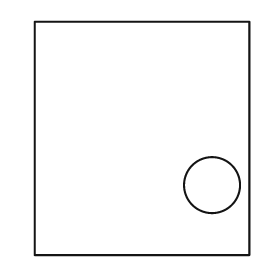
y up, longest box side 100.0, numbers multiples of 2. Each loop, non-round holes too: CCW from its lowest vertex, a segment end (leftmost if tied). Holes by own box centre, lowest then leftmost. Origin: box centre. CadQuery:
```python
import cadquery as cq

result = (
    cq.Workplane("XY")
    .moveTo(-46.0, -50.0)
    .lineTo(46.0, -50.0)
    .lineTo(46.0, 50.0)
    .lineTo(-46.0, 50.0)
    .close()
    .moveTo(30.0, -20.0)
    .circle(12.0)
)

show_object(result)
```